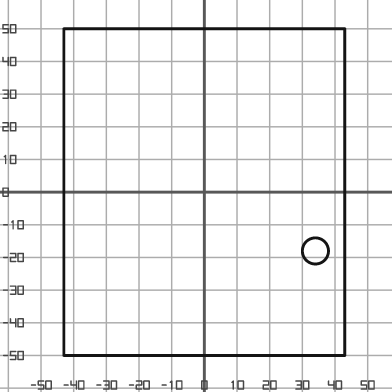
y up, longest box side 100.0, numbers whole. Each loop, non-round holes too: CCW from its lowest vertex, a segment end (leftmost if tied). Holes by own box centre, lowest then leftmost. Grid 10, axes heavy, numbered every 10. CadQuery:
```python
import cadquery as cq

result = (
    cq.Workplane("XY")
    .moveTo(-43.0, -50.0)
    .lineTo(43.0, -50.0)
    .lineTo(43.0, 50.0)
    .lineTo(-43.0, 50.0)
    .close()
    .moveTo(34.0, -18.0)
    .circle(4.0)
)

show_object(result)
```